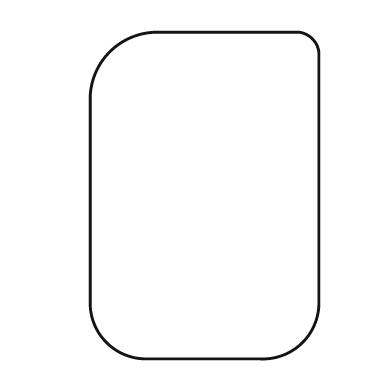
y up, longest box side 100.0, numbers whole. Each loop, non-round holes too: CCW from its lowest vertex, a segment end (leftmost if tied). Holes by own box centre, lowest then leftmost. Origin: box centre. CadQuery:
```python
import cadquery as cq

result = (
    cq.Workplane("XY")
    .moveTo(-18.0, -50.0)
    .lineTo(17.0, -50.0)
    .threePointArc((30.0, -45.0), (35.0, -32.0))
    .lineTo(35.0, 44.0)
    .threePointArc((33.0, 48.0), (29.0, 50.0))
    .lineTo(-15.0, 50.0)
    .threePointArc((-29.0, 44.0), (-35.0, 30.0))
    .lineTo(-35.0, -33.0)
    .threePointArc((-30.0, -45.0), (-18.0, -50.0))
    .close()
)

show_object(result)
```